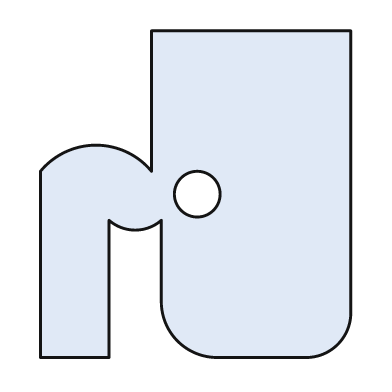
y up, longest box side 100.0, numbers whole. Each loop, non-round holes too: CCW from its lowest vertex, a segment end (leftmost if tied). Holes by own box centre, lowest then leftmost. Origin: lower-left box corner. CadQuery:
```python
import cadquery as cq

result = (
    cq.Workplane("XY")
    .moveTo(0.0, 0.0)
    .lineTo(21.0, 0.0)
    .lineTo(21.0, 42.0)
    .threePointArc((29.0, 39.0), (37.0, 42.0))
    .lineTo(37.0, 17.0)
    .threePointArc((42.0, 5.0), (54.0, 0.0))
    .lineTo(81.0, 0.0)
    .threePointArc((91.0, 4.0), (95.0, 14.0))
    .lineTo(95.0, 100.0)
    .lineTo(34.0, 100.0)
    .lineTo(34.0, 57.0)
    .threePointArc((17.0, 65.0), (0.0, 57.0))
    .close()
    .moveTo(48.0, 50.0)
    .circle(7.0)
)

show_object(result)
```